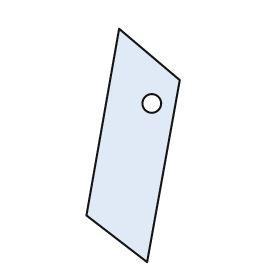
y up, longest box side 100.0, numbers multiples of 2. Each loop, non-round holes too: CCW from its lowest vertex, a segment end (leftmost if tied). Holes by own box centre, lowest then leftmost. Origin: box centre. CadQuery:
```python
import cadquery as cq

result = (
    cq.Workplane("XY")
    .moveTo(6.0, -50.0)
    .lineTo(20.0, 28.0)
    .lineTo(-6.0, 50.0)
    .lineTo(-20.0, -30.0)
    .close()
    .moveTo(8.0, 18.0)
    .circle(4.0)
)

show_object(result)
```